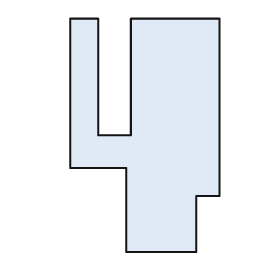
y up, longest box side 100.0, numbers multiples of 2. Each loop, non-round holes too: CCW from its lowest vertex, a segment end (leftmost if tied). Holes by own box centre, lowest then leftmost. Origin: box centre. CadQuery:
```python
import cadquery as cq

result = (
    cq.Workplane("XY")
    .moveTo(-8.0, -50.0)
    .lineTo(22.0, -50.0)
    .lineTo(22.0, -26.0)
    .lineTo(32.0, -26.0)
    .lineTo(32.0, 50.0)
    .lineTo(-6.0, 50.0)
    .lineTo(-6.0, 0.0)
    .lineTo(-20.0, 0.0)
    .lineTo(-20.0, 50.0)
    .lineTo(-32.0, 50.0)
    .lineTo(-32.0, -14.0)
    .lineTo(-8.0, -14.0)
    .close()
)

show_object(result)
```